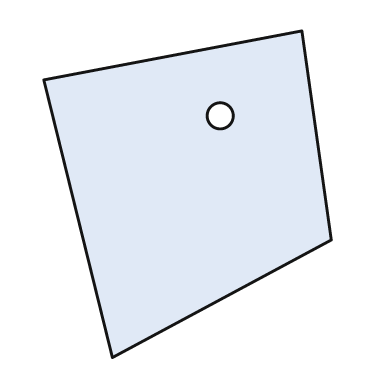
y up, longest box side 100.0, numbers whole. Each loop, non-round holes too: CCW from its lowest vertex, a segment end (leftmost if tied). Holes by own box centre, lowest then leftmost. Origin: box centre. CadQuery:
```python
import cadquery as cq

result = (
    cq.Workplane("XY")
    .moveTo(-23.0, -50.0)
    .lineTo(44.0, -14.0)
    .lineTo(35.0, 50.0)
    .lineTo(-44.0, 35.0)
    .close()
    .moveTo(10.0, 24.0)
    .circle(4.0)
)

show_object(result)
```